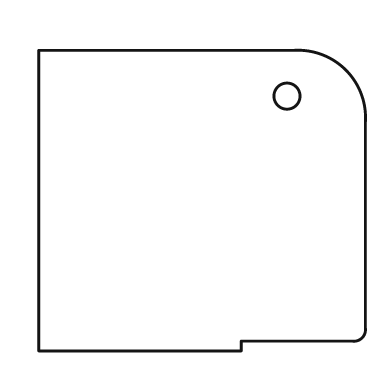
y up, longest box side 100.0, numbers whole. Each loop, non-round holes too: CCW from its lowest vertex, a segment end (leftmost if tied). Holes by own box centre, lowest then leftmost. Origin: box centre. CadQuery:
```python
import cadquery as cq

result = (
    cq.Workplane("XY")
    .moveTo(-50.0, -46.0)
    .lineTo(12.0, -46.0)
    .lineTo(12.0, -43.0)
    .lineTo(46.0, -43.0)
    .threePointArc((49.0, -42.0), (50.0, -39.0))
    .lineTo(50.0, 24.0)
    .threePointArc((44.0, 40.0), (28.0, 46.0))
    .lineTo(-50.0, 46.0)
    .close()
    .moveTo(26.0, 32.0)
    .circle(4.0)
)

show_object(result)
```